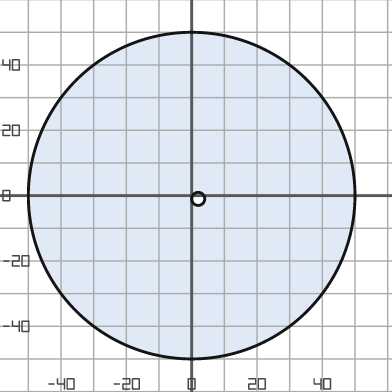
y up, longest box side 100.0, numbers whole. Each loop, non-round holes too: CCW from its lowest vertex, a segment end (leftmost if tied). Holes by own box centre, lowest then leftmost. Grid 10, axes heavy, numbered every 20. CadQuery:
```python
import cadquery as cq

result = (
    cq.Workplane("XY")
    .moveTo(0.0, 0.0)
    .circle(50.0)
    .moveTo(2.0, -1.0)
    .circle(2.0)
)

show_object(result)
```